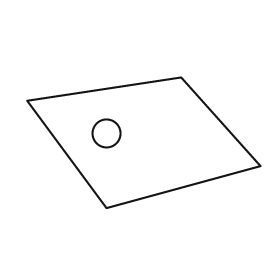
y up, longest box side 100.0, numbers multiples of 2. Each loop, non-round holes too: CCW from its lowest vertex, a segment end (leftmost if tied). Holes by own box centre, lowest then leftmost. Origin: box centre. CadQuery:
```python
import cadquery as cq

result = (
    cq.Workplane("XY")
    .moveTo(-16.0, -28.0)
    .lineTo(50.0, -10.0)
    .lineTo(16.0, 28.0)
    .lineTo(-50.0, 18.0)
    .close()
    .moveTo(-16.0, 4.0)
    .circle(6.0)
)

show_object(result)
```